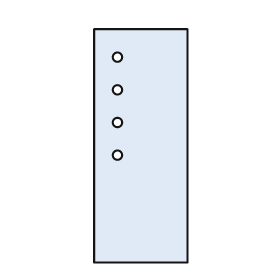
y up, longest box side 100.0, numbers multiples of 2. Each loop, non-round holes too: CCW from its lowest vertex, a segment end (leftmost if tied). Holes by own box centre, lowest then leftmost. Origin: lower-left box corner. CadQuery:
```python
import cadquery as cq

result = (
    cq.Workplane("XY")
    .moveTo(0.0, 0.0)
    .lineTo(40.0, 0.0)
    .lineTo(40.0, 100.0)
    .lineTo(0.0, 100.0)
    .close()
    .moveTo(10.0, 46.0)
    .circle(2.0)
    .moveTo(10.0, 60.0)
    .circle(2.0)
    .moveTo(10.0, 74.0)
    .circle(2.0)
    .moveTo(10.0, 88.0)
    .circle(2.0)
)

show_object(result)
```